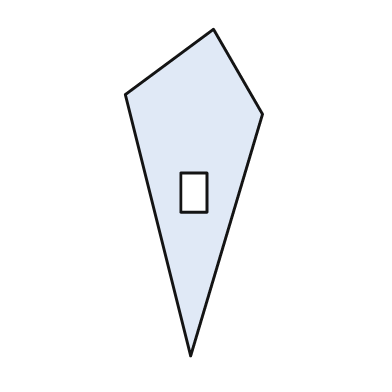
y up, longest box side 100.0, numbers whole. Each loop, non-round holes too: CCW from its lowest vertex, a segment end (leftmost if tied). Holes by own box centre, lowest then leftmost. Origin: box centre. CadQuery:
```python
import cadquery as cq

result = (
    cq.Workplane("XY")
    .moveTo(-1.0, -50.0)
    .lineTo(21.0, 24.0)
    .lineTo(6.0, 50.0)
    .lineTo(-21.0, 30.0)
    .close()
    .moveTo(-4.0, -6.0)
    .lineTo(4.0, -6.0)
    .lineTo(4.0, 6.0)
    .lineTo(-4.0, 6.0)
    .close()
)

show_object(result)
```